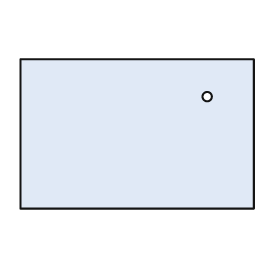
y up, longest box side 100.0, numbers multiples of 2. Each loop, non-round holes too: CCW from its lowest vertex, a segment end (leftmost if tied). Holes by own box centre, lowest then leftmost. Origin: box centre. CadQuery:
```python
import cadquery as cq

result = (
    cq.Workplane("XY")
    .moveTo(-50.0, -32.0)
    .lineTo(50.0, -32.0)
    .lineTo(50.0, 32.0)
    .lineTo(-50.0, 32.0)
    .close()
    .moveTo(30.0, 16.0)
    .circle(2.0)
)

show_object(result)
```